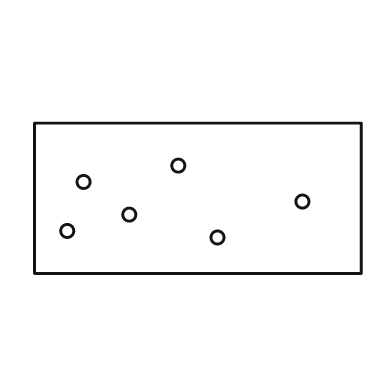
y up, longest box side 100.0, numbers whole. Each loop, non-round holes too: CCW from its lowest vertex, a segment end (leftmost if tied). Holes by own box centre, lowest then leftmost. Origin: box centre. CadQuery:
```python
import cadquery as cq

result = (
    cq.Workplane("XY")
    .moveTo(-50.0, -23.0)
    .lineTo(50.0, -23.0)
    .lineTo(50.0, 23.0)
    .lineTo(-50.0, 23.0)
    .close()
    .moveTo(6.0, -12.0)
    .circle(2.0)
    .moveTo(-40.0, -10.0)
    .circle(2.0)
    .moveTo(-21.0, -5.0)
    .circle(2.0)
    .moveTo(32.0, -1.0)
    .circle(2.0)
    .moveTo(-35.0, 5.0)
    .circle(2.0)
    .moveTo(-6.0, 10.0)
    .circle(2.0)
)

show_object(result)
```